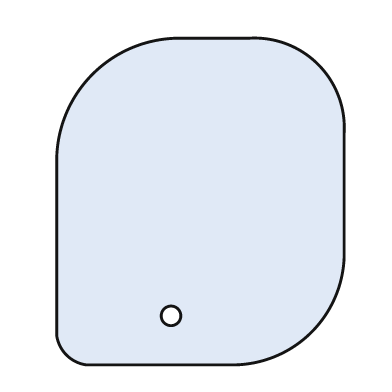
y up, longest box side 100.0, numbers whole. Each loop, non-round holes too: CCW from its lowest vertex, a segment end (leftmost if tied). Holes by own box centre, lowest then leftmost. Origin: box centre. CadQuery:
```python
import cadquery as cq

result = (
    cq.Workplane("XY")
    .moveTo(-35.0, -50.0)
    .lineTo(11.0, -50.0)
    .threePointArc((34.0, -40.0), (44.0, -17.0))
    .lineTo(44.0, 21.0)
    .threePointArc((36.0, 42.0), (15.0, 50.0))
    .lineTo(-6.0, 50.0)
    .threePointArc((-33.0, 39.0), (-44.0, 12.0))
    .lineTo(-44.0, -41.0)
    .threePointArc((-41.0, -47.0), (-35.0, -50.0))
    .close()
    .moveTo(-9.0, -35.0)
    .circle(3.0)
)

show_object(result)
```